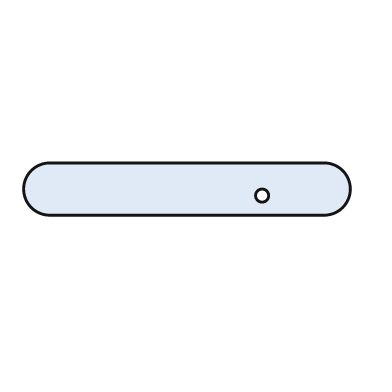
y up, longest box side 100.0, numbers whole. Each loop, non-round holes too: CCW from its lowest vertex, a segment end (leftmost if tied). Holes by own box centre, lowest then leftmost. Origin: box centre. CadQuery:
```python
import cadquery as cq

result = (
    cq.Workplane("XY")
    .moveTo(-42.0, -8.0)
    .lineTo(42.0, -8.0)
    .threePointArc((50.0, 0.0), (42.0, 8.0))
    .lineTo(-42.0, 8.0)
    .threePointArc((-50.0, 0.0), (-42.0, -8.0))
    .close()
    .moveTo(23.0, -2.0)
    .circle(2.0)
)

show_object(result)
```